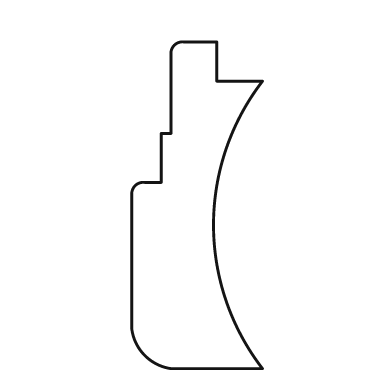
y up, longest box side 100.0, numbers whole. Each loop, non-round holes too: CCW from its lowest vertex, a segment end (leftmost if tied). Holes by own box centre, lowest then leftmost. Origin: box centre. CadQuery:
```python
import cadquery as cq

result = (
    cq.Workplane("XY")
    .moveTo(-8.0, -50.0)
    .lineTo(20.0, -50.0)
    .threePointArc((5.0, -6.0), (20.0, 38.0))
    .lineTo(6.0, 38.0)
    .lineTo(6.0, 50.0)
    .lineTo(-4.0, 50.0)
    .threePointArc((-7.0, 49.0), (-8.0, 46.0))
    .lineTo(-8.0, 22.0)
    .lineTo(-11.0, 22.0)
    .lineTo(-11.0, 7.0)
    .lineTo(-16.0, 7.0)
    .threePointArc((-19.0, 6.0), (-20.0, 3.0))
    .lineTo(-20.0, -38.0)
    .threePointArc((-16.0, -46.0), (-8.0, -50.0))
    .close()
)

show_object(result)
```